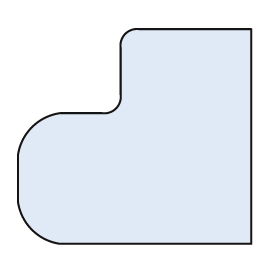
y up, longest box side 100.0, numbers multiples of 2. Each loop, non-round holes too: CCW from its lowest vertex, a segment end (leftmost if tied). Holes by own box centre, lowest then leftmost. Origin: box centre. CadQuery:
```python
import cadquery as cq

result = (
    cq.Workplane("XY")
    .moveTo(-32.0, -46.0)
    .lineTo(50.0, -46.0)
    .lineTo(50.0, 46.0)
    .lineTo(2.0, 46.0)
    .threePointArc((-4.0, 44.0), (-6.0, 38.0))
    .lineTo(-6.0, 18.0)
    .threePointArc((-8.0, 12.0), (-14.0, 10.0))
    .lineTo(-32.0, 10.0)
    .threePointArc((-44.0, 4.0), (-50.0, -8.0))
    .lineTo(-50.0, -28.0)
    .threePointArc((-44.0, -40.0), (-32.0, -46.0))
    .close()
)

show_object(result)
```